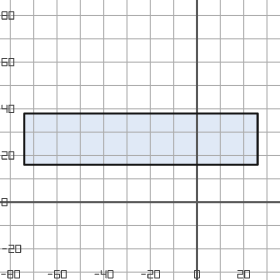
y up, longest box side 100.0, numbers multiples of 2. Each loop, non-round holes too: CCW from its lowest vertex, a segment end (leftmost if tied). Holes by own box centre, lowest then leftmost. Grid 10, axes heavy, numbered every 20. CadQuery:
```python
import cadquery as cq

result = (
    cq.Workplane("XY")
    .moveTo(-74.0, 16.0)
    .lineTo(26.0, 16.0)
    .lineTo(26.0, 38.0)
    .lineTo(-74.0, 38.0)
    .close()
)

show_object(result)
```